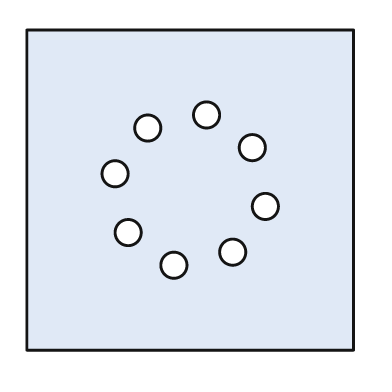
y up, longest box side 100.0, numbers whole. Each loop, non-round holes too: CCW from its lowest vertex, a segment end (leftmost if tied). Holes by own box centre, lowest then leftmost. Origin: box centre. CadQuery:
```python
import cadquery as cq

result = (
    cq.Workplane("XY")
    .moveTo(-50.0, -49.0)
    .lineTo(50.0, -49.0)
    .lineTo(50.0, 49.0)
    .lineTo(-50.0, 49.0)
    .close()
    .moveTo(-5.0, -23.0)
    .circle(4.0)
    .moveTo(13.0, -19.0)
    .circle(4.0)
    .moveTo(-19.0, -13.0)
    .circle(4.0)
    .moveTo(23.0, -5.0)
    .circle(4.0)
    .moveTo(-23.0, 5.0)
    .circle(4.0)
    .moveTo(19.0, 13.0)
    .circle(4.0)
    .moveTo(-13.0, 19.0)
    .circle(4.0)
    .moveTo(5.0, 23.0)
    .circle(4.0)
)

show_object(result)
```